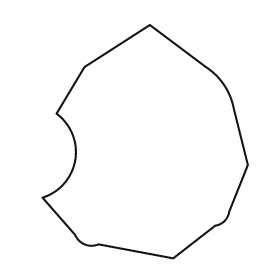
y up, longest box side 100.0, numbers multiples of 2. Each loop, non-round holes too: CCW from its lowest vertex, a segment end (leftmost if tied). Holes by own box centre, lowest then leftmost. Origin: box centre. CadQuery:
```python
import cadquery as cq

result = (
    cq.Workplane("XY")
    .moveTo(12.0, -50.0)
    .lineTo(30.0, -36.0)
    .threePointArc((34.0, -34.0), (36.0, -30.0))
    .lineTo(44.0, -10.0)
    .lineTo(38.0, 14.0)
    .threePointArc((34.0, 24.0), (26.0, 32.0))
    .lineTo(2.0, 50.0)
    .lineTo(-26.0, 32.0)
    .lineTo(-38.0, 12.0)
    .threePointArc((-30.0, -8.0), (-44.0, -24.0))
    .lineTo(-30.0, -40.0)
    .threePointArc((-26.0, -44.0), (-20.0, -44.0))
    .close()
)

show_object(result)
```